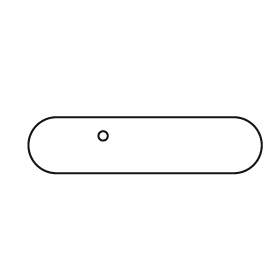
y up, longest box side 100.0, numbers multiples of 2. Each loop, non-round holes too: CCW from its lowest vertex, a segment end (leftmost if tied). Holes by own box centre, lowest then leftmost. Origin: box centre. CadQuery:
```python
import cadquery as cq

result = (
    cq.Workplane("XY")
    .moveTo(-38.0, -12.0)
    .lineTo(38.0, -12.0)
    .threePointArc((50.0, 0.0), (38.0, 12.0))
    .lineTo(-38.0, 12.0)
    .threePointArc((-50.0, 0.0), (-38.0, -12.0))
    .close()
    .moveTo(-18.0, 4.0)
    .circle(2.0)
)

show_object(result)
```